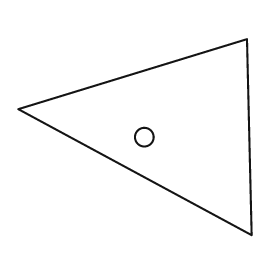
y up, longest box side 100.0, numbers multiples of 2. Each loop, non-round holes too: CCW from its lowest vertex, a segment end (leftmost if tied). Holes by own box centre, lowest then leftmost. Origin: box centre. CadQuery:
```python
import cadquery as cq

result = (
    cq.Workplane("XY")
    .moveTo(50.0, -42.0)
    .lineTo(48.0, 42.0)
    .lineTo(-50.0, 12.0)
    .close()
    .moveTo(4.0, 0.0)
    .circle(4.0)
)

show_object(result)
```